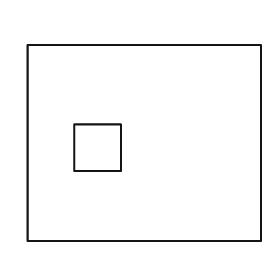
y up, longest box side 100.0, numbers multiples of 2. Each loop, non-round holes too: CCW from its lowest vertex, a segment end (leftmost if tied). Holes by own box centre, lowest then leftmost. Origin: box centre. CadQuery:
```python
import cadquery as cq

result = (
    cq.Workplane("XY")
    .moveTo(-50.0, -42.0)
    .lineTo(50.0, -42.0)
    .lineTo(50.0, 42.0)
    .lineTo(-50.0, 42.0)
    .close()
    .moveTo(-30.0, -12.0)
    .lineTo(-10.0, -12.0)
    .lineTo(-10.0, 8.0)
    .lineTo(-30.0, 8.0)
    .close()
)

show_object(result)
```